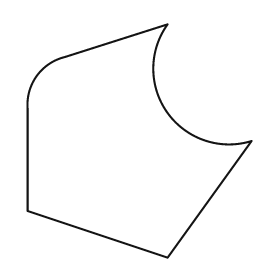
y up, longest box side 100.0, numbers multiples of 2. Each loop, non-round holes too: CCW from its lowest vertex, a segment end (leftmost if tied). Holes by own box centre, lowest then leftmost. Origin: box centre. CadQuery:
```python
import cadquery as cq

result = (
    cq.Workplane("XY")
    .moveTo(12.0, -50.0)
    .lineTo(48.0, 0.0)
    .threePointArc((12.0, 12.0), (12.0, 50.0))
    .lineTo(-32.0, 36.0)
    .threePointArc((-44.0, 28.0), (-48.0, 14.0))
    .lineTo(-48.0, -30.0)
    .close()
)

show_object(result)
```